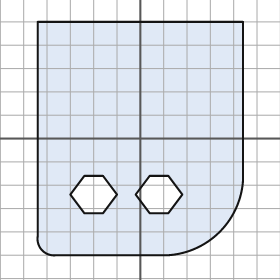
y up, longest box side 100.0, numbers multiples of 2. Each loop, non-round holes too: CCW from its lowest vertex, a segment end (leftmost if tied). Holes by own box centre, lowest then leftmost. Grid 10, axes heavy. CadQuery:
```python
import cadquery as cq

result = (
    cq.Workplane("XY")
    .moveTo(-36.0, -50.0)
    .lineTo(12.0, -50.0)
    .threePointArc((34.0, -40.0), (44.0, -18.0))
    .lineTo(44.0, 50.0)
    .lineTo(-44.0, 50.0)
    .lineTo(-44.0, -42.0)
    .threePointArc((-42.0, -48.0), (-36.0, -50.0))
    .close()
    .moveTo(-24.0, -32.0)
    .lineTo(-16.0, -32.0)
    .lineTo(-10.0, -24.0)
    .lineTo(-16.0, -16.0)
    .lineTo(-24.0, -16.0)
    .lineTo(-30.0, -24.0)
    .close()
    .moveTo(4.0, -32.0)
    .lineTo(12.0, -32.0)
    .lineTo(18.0, -24.0)
    .lineTo(12.0, -16.0)
    .lineTo(4.0, -16.0)
    .lineTo(-2.0, -24.0)
    .close()
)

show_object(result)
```